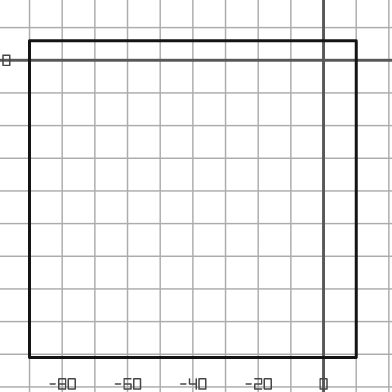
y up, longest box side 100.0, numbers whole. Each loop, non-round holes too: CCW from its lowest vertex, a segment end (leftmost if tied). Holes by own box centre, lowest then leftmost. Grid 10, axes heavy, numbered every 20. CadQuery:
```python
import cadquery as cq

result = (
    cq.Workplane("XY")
    .moveTo(-90.0, -91.0)
    .lineTo(10.0, -91.0)
    .lineTo(10.0, 6.0)
    .lineTo(-90.0, 6.0)
    .close()
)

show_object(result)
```